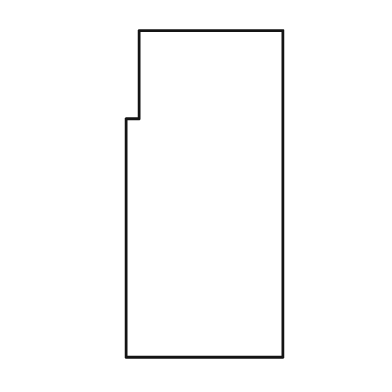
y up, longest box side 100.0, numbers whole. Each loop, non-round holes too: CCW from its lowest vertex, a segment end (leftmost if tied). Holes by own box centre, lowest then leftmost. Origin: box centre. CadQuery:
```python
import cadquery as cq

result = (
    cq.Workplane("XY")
    .moveTo(-24.0, -50.0)
    .lineTo(24.0, -50.0)
    .lineTo(24.0, 50.0)
    .lineTo(-20.0, 50.0)
    .lineTo(-20.0, 23.0)
    .lineTo(-24.0, 23.0)
    .close()
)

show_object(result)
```